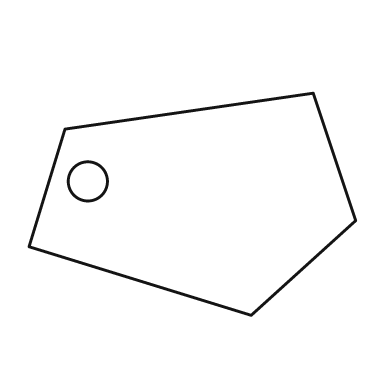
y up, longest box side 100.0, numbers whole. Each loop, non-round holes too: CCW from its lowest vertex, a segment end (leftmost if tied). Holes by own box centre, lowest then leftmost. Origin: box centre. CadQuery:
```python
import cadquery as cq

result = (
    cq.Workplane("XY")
    .moveTo(18.0, -34.0)
    .lineTo(50.0, -5.0)
    .lineTo(37.0, 34.0)
    .lineTo(-39.0, 23.0)
    .lineTo(-50.0, -13.0)
    .close()
    .moveTo(-32.0, 7.0)
    .circle(6.0)
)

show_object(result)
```